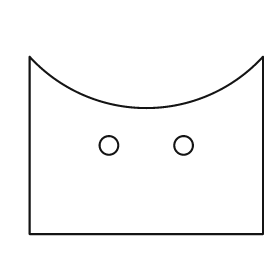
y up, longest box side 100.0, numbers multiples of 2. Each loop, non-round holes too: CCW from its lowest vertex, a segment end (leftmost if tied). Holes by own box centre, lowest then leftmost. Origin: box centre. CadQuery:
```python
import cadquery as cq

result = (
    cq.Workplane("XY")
    .moveTo(-50.0, -38.0)
    .lineTo(50.0, -38.0)
    .lineTo(50.0, 38.0)
    .threePointArc((0.0, 16.0), (-50.0, 38.0))
    .close()
    .moveTo(-16.0, 0.0)
    .circle(4.0)
    .moveTo(16.0, 0.0)
    .circle(4.0)
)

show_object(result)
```